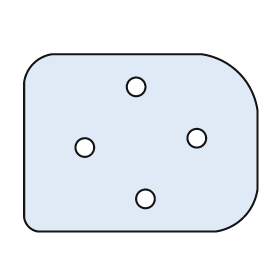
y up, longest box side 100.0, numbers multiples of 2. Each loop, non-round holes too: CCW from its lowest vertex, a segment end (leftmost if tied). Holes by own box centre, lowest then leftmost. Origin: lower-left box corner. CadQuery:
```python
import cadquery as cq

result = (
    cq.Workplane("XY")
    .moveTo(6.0, 0.0)
    .lineTo(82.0, 0.0)
    .threePointArc((94.0, 6.0), (100.0, 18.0))
    .lineTo(100.0, 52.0)
    .threePointArc((92.0, 68.0), (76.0, 76.0))
    .lineTo(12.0, 76.0)
    .threePointArc((4.0, 72.0), (0.0, 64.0))
    .lineTo(0.0, 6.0)
    .threePointArc((2.0, 2.0), (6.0, 0.0))
    .close()
    .moveTo(52.0, 14.0)
    .circle(4.0)
    .moveTo(26.0, 36.0)
    .circle(4.0)
    .moveTo(74.0, 40.0)
    .circle(4.0)
    .moveTo(48.0, 62.0)
    .circle(4.0)
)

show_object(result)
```